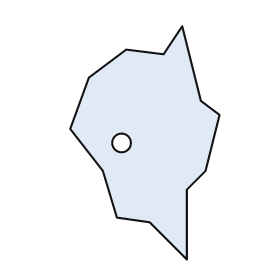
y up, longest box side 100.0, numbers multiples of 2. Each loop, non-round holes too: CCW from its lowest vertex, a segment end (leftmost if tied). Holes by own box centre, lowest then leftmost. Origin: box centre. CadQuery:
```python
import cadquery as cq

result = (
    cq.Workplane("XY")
    .moveTo(18.0, -50.0)
    .lineTo(18.0, -20.0)
    .lineTo(26.0, -12.0)
    .lineTo(32.0, 12.0)
    .lineTo(24.0, 18.0)
    .lineTo(16.0, 50.0)
    .lineTo(8.0, 38.0)
    .lineTo(-8.0, 40.0)
    .lineTo(-24.0, 28.0)
    .lineTo(-32.0, 6.0)
    .lineTo(-18.0, -12.0)
    .lineTo(-12.0, -32.0)
    .lineTo(2.0, -34.0)
    .close()
    .moveTo(-10.0, 0.0)
    .circle(4.0)
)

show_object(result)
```